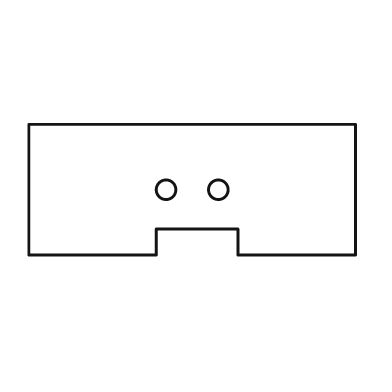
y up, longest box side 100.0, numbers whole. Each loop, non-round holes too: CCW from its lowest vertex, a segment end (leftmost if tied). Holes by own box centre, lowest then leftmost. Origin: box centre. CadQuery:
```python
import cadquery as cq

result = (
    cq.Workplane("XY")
    .moveTo(-50.0, -20.0)
    .lineTo(-11.0, -20.0)
    .lineTo(-11.0, -12.0)
    .lineTo(14.0, -12.0)
    .lineTo(14.0, -20.0)
    .lineTo(50.0, -20.0)
    .lineTo(50.0, 20.0)
    .lineTo(-50.0, 20.0)
    .close()
    .moveTo(-8.0, 0.0)
    .circle(3.0)
    .moveTo(8.0, 0.0)
    .circle(3.0)
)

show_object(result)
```